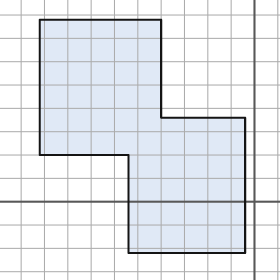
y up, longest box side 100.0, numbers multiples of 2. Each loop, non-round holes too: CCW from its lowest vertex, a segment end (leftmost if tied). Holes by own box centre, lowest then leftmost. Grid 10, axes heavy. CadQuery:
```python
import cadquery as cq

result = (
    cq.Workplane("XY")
    .moveTo(-54.0, -22.0)
    .lineTo(-4.0, -22.0)
    .lineTo(-4.0, 36.0)
    .lineTo(-40.0, 36.0)
    .lineTo(-40.0, 78.0)
    .lineTo(-92.0, 78.0)
    .lineTo(-92.0, 20.0)
    .lineTo(-54.0, 20.0)
    .close()
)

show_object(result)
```